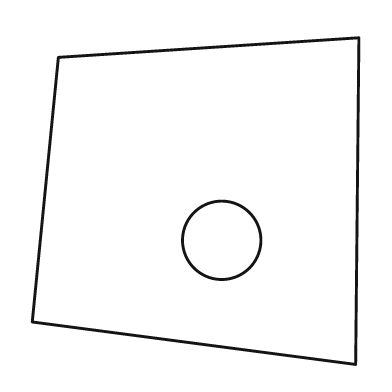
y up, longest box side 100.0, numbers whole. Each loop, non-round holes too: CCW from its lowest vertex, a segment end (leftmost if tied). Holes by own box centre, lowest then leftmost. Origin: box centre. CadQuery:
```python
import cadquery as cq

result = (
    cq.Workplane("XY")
    .moveTo(49.0, -50.0)
    .lineTo(50.0, 50.0)
    .lineTo(-42.0, 44.0)
    .lineTo(-50.0, -37.0)
    .close()
    .moveTo(8.0, -12.0)
    .circle(12.0)
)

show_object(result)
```